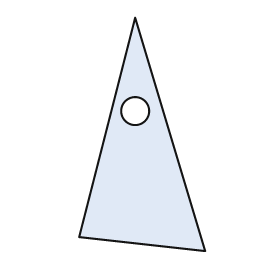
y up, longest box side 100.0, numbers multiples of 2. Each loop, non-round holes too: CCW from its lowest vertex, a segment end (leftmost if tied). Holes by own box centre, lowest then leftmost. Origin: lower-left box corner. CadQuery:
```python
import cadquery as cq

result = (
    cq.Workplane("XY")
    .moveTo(54.0, 0.0)
    .lineTo(24.0, 100.0)
    .lineTo(0.0, 6.0)
    .close()
    .moveTo(24.0, 60.0)
    .circle(6.0)
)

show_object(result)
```